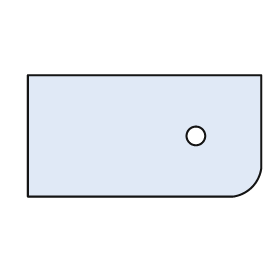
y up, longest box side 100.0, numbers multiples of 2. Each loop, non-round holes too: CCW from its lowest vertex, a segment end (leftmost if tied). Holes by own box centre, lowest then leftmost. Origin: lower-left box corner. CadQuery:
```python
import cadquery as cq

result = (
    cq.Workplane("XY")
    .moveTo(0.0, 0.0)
    .lineTo(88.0, 0.0)
    .threePointArc((96.0, 4.0), (100.0, 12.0))
    .lineTo(100.0, 52.0)
    .lineTo(0.0, 52.0)
    .close()
    .moveTo(72.0, 26.0)
    .circle(4.0)
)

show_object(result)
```